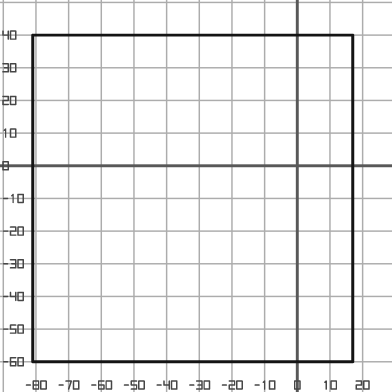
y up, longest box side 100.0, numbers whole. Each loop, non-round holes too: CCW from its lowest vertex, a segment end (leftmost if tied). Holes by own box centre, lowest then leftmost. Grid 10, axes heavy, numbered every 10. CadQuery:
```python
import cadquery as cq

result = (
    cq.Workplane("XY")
    .moveTo(-81.0, -60.0)
    .lineTo(17.0, -60.0)
    .lineTo(17.0, 40.0)
    .lineTo(-81.0, 40.0)
    .close()
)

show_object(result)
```